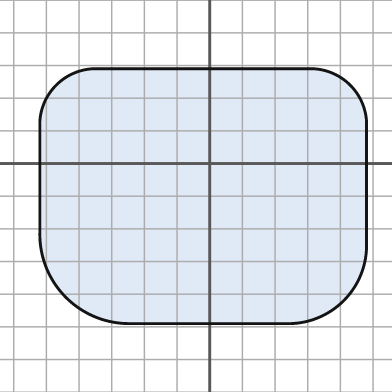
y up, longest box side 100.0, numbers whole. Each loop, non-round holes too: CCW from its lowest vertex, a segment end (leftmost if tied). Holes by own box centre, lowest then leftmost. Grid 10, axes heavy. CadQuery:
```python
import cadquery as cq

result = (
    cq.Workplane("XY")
    .moveTo(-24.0, -49.0)
    .lineTo(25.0, -49.0)
    .threePointArc((41.0, -42.0), (48.0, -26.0))
    .lineTo(48.0, 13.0)
    .threePointArc((43.0, 24.0), (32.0, 29.0))
    .lineTo(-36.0, 29.0)
    .threePointArc((-47.0, 24.0), (-52.0, 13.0))
    .lineTo(-52.0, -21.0)
    .threePointArc((-44.0, -41.0), (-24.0, -49.0))
    .close()
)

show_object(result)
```